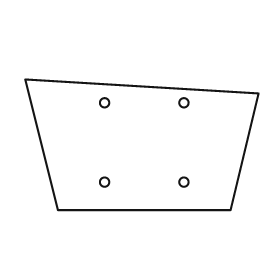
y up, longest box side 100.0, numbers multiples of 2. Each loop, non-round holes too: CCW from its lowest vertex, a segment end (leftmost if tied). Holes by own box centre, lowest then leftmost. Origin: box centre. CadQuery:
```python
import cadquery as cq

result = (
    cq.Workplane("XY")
    .moveTo(-36.0, -28.0)
    .lineTo(38.0, -28.0)
    .lineTo(50.0, 22.0)
    .lineTo(-50.0, 28.0)
    .close()
    .moveTo(-16.0, -16.0)
    .circle(2.0)
    .moveTo(18.0, -16.0)
    .circle(2.0)
    .moveTo(-16.0, 18.0)
    .circle(2.0)
    .moveTo(18.0, 18.0)
    .circle(2.0)
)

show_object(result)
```